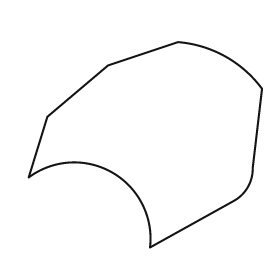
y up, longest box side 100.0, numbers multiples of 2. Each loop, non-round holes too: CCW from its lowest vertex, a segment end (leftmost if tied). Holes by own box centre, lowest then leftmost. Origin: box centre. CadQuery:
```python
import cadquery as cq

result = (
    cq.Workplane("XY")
    .moveTo(2.0, -44.0)
    .lineTo(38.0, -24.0)
    .threePointArc((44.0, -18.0), (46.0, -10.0))
    .lineTo(50.0, 24.0)
    .threePointArc((34.0, 38.0), (14.0, 44.0))
    .lineTo(-16.0, 34.0)
    .lineTo(-42.0, 12.0)
    .lineTo(-50.0, -14.0)
    .threePointArc((-14.0, -12.0), (2.0, -44.0))
    .close()
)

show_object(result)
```